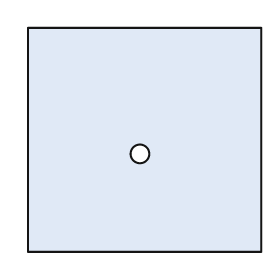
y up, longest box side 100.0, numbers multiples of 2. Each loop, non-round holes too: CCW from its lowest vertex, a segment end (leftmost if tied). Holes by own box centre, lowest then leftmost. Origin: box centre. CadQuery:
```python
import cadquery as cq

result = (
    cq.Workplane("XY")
    .moveTo(-50.0, -48.0)
    .lineTo(50.0, -48.0)
    .lineTo(50.0, 48.0)
    .lineTo(-50.0, 48.0)
    .close()
    .moveTo(-2.0, -6.0)
    .circle(4.0)
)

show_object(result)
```